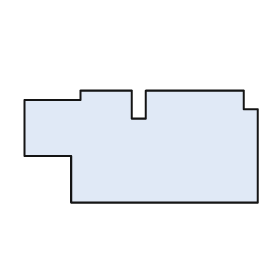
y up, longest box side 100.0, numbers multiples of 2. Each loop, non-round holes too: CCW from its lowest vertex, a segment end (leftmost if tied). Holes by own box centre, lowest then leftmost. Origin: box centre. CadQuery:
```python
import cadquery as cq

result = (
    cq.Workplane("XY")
    .moveTo(-30.0, -24.0)
    .lineTo(50.0, -24.0)
    .lineTo(50.0, 16.0)
    .lineTo(44.0, 16.0)
    .lineTo(44.0, 24.0)
    .lineTo(2.0, 24.0)
    .lineTo(2.0, 12.0)
    .lineTo(-4.0, 12.0)
    .lineTo(-4.0, 24.0)
    .lineTo(-26.0, 24.0)
    .lineTo(-26.0, 20.0)
    .lineTo(-50.0, 20.0)
    .lineTo(-50.0, -4.0)
    .lineTo(-30.0, -4.0)
    .close()
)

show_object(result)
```